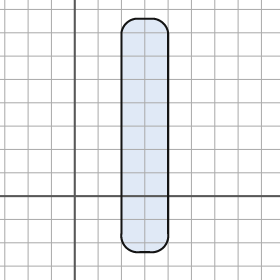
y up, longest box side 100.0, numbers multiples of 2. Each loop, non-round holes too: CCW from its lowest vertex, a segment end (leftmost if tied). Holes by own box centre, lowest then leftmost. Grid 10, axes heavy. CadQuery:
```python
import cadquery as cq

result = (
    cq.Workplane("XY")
    .moveTo(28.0, -24.0)
    .lineTo(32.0, -24.0)
    .threePointArc((38.0, -22.0), (40.0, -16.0))
    .lineTo(40.0, 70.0)
    .threePointArc((38.0, 74.0), (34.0, 76.0))
    .lineTo(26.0, 76.0)
    .threePointArc((22.0, 74.0), (20.0, 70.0))
    .lineTo(20.0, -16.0)
    .threePointArc((22.0, -22.0), (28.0, -24.0))
    .close()
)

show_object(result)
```